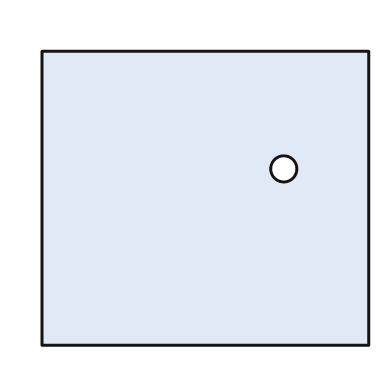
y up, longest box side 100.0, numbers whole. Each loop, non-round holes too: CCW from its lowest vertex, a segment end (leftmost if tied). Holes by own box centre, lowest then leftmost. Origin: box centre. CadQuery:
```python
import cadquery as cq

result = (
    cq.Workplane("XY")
    .moveTo(-50.0, -45.0)
    .lineTo(50.0, -45.0)
    .lineTo(50.0, 45.0)
    .lineTo(-50.0, 45.0)
    .close()
    .moveTo(24.0, 9.0)
    .circle(4.0)
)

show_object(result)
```